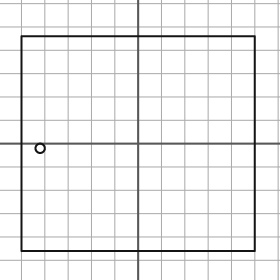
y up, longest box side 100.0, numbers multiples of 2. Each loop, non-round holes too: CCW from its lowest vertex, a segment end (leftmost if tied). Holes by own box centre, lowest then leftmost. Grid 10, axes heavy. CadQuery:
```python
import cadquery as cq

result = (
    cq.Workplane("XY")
    .moveTo(-50.0, -46.0)
    .lineTo(50.0, -46.0)
    .lineTo(50.0, 46.0)
    .lineTo(-50.0, 46.0)
    .close()
    .moveTo(-42.0, -2.0)
    .circle(2.0)
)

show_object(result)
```